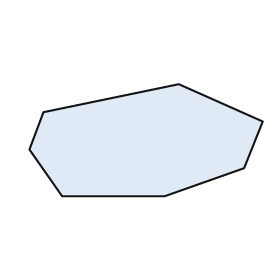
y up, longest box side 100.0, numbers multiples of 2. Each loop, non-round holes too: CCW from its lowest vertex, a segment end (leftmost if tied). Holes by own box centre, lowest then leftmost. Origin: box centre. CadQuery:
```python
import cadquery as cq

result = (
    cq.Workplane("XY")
    .moveTo(-36.0, -24.0)
    .lineTo(8.0, -24.0)
    .lineTo(42.0, -12.0)
    .lineTo(50.0, 8.0)
    .lineTo(14.0, 24.0)
    .lineTo(-44.0, 12.0)
    .lineTo(-50.0, -4.0)
    .close()
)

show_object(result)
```